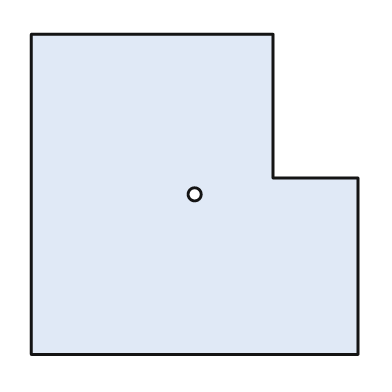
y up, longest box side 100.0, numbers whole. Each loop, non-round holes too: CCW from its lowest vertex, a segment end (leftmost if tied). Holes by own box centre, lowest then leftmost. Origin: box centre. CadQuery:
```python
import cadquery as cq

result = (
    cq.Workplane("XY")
    .moveTo(-50.0, -49.0)
    .lineTo(50.0, -49.0)
    .lineTo(50.0, 5.0)
    .lineTo(24.0, 5.0)
    .lineTo(24.0, 49.0)
    .lineTo(-50.0, 49.0)
    .close()
    .moveTo(0.0, 0.0)
    .circle(2.0)
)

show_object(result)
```